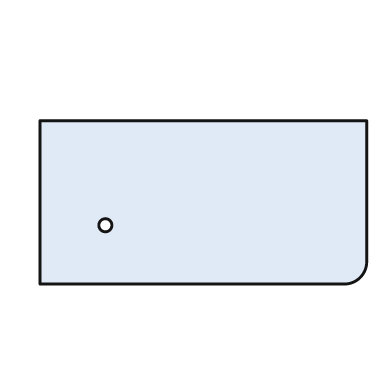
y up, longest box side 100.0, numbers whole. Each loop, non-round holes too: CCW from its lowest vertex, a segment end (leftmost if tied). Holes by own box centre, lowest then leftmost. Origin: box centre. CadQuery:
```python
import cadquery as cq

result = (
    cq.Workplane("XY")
    .moveTo(-50.0, -25.0)
    .lineTo(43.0, -25.0)
    .threePointArc((48.0, -23.0), (50.0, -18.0))
    .lineTo(50.0, 25.0)
    .lineTo(-50.0, 25.0)
    .close()
    .moveTo(-30.0, -7.0)
    .circle(2.0)
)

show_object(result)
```